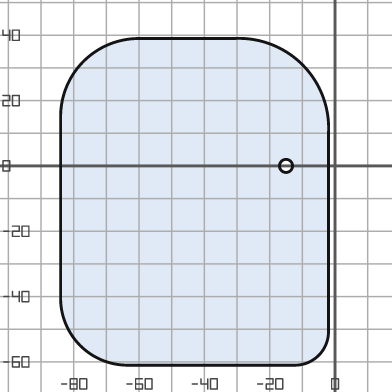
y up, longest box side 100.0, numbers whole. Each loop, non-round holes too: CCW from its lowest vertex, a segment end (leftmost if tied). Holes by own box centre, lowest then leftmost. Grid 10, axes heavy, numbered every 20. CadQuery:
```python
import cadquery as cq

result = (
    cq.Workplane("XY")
    .moveTo(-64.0, -61.0)
    .lineTo(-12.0, -61.0)
    .threePointArc((-5.0, -58.0), (-2.0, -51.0))
    .lineTo(-2.0, 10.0)
    .threePointArc((-10.0, 31.0), (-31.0, 39.0))
    .lineTo(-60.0, 39.0)
    .threePointArc((-77.0, 32.0), (-84.0, 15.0))
    .lineTo(-84.0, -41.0)
    .threePointArc((-78.0, -55.0), (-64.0, -61.0))
    .close()
    .moveTo(-15.0, 0.0)
    .circle(2.0)
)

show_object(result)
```